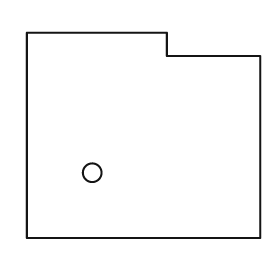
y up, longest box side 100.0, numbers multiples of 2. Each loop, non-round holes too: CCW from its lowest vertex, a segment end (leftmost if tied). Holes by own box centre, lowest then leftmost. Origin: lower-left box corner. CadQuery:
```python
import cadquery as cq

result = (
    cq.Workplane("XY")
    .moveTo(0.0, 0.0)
    .lineTo(100.0, 0.0)
    .lineTo(100.0, 78.0)
    .lineTo(60.0, 78.0)
    .lineTo(60.0, 88.0)
    .lineTo(0.0, 88.0)
    .close()
    .moveTo(28.0, 28.0)
    .circle(4.0)
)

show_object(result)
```